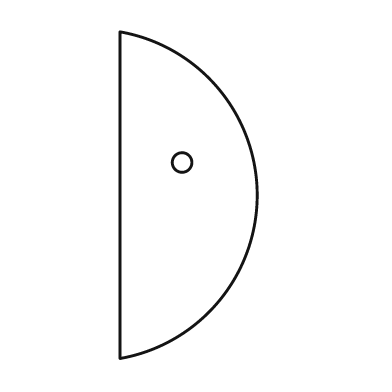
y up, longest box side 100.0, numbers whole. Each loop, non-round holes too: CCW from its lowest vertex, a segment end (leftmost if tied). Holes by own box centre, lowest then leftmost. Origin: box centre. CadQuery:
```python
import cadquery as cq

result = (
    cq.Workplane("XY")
    .moveTo(-21.0, -50.0)
    .threePointArc((21.0, 0.0), (-21.0, 50.0))
    .close()
    .moveTo(-2.0, 10.0)
    .circle(3.0)
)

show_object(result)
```